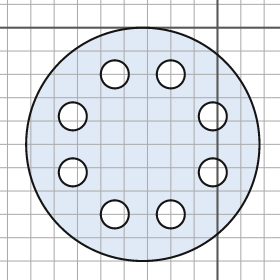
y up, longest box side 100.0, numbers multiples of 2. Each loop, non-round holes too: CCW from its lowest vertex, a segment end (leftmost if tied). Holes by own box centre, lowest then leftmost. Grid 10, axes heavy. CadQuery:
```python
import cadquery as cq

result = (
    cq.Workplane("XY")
    .moveTo(-32.0, -50.0)
    .circle(50.0)
    .moveTo(-44.0, -80.0)
    .circle(6.0)
    .moveTo(-20.0, -80.0)
    .circle(6.0)
    .moveTo(-62.0, -62.0)
    .circle(6.0)
    .moveTo(-2.0, -62.0)
    .circle(6.0)
    .moveTo(-62.0, -38.0)
    .circle(6.0)
    .moveTo(-2.0, -38.0)
    .circle(6.0)
    .moveTo(-44.0, -20.0)
    .circle(6.0)
    .moveTo(-20.0, -20.0)
    .circle(6.0)
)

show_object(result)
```